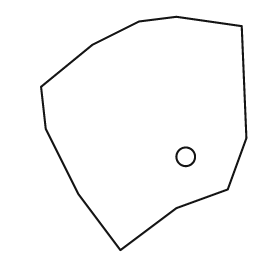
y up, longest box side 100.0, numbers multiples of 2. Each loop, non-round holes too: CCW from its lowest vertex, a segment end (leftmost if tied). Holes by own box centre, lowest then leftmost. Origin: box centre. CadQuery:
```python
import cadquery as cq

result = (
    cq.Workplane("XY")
    .moveTo(-10.0, -50.0)
    .lineTo(14.0, -32.0)
    .lineTo(36.0, -24.0)
    .lineTo(44.0, -2.0)
    .lineTo(42.0, 46.0)
    .lineTo(14.0, 50.0)
    .lineTo(-2.0, 48.0)
    .lineTo(-22.0, 38.0)
    .lineTo(-44.0, 20.0)
    .lineTo(-42.0, 2.0)
    .lineTo(-28.0, -26.0)
    .close()
    .moveTo(18.0, -10.0)
    .circle(4.0)
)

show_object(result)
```